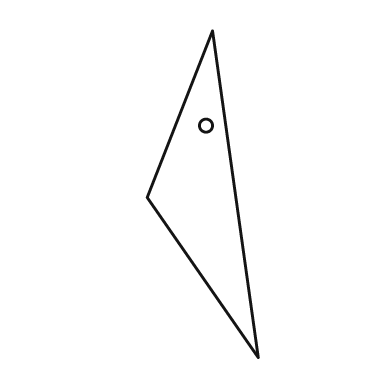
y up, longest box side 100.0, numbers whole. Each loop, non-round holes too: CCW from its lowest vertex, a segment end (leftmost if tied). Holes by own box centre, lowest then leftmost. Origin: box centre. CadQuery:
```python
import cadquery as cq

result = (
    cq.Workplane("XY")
    .moveTo(17.0, -50.0)
    .lineTo(3.0, 50.0)
    .lineTo(-17.0, -1.0)
    .close()
    .moveTo(1.0, 21.0)
    .circle(2.0)
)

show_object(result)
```